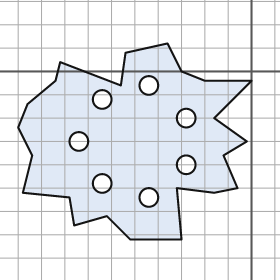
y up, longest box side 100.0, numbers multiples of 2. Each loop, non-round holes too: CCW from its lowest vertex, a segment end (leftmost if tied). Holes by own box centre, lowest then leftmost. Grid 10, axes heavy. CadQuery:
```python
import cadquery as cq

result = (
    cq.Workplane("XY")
    .moveTo(-52.0, -72.0)
    .lineTo(-30.0, -72.0)
    .lineTo(-32.0, -50.0)
    .lineTo(-16.0, -52.0)
    .lineTo(-6.0, -50.0)
    .lineTo(-12.0, -36.0)
    .lineTo(-2.0, -30.0)
    .lineTo(-16.0, -20.0)
    .lineTo(0.0, -4.0)
    .lineTo(-20.0, -4.0)
    .lineTo(-30.0, 0.0)
    .lineTo(-36.0, 12.0)
    .lineTo(-54.0, 8.0)
    .lineTo(-56.0, -6.0)
    .lineTo(-82.0, 4.0)
    .lineTo(-84.0, -4.0)
    .lineTo(-96.0, -14.0)
    .lineTo(-100.0, -24.0)
    .lineTo(-94.0, -36.0)
    .lineTo(-98.0, -52.0)
    .lineTo(-78.0, -54.0)
    .lineTo(-76.0, -66.0)
    .lineTo(-62.0, -62.0)
    .close()
    .moveTo(-44.0, -54.0)
    .circle(4.0)
    .moveTo(-64.0, -48.0)
    .circle(4.0)
    .moveTo(-28.0, -40.0)
    .circle(4.0)
    .moveTo(-74.0, -30.0)
    .circle(4.0)
    .moveTo(-28.0, -20.0)
    .circle(4.0)
    .moveTo(-64.0, -12.0)
    .circle(4.0)
    .moveTo(-44.0, -6.0)
    .circle(4.0)
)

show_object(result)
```